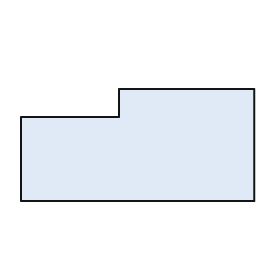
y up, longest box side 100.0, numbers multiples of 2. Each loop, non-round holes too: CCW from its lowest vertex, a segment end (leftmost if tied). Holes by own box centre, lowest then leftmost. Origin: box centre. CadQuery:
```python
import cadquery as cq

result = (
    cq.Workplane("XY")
    .moveTo(-50.0, -24.0)
    .lineTo(50.0, -24.0)
    .lineTo(50.0, 24.0)
    .lineTo(-8.0, 24.0)
    .lineTo(-8.0, 12.0)
    .lineTo(-50.0, 12.0)
    .close()
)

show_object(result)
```